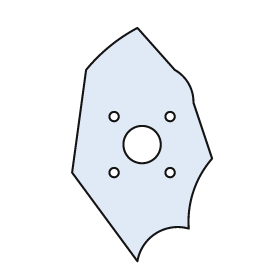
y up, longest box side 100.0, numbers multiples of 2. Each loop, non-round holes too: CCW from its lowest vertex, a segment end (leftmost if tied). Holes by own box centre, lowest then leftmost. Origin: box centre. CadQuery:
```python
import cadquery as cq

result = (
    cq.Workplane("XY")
    .moveTo(-2.0, -50.0)
    .threePointArc((6.0, -38.0), (20.0, -36.0))
    .threePointArc((22.0, -20.0), (30.0, -6.0))
    .lineTo(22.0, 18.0)
    .threePointArc((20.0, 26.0), (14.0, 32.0))
    .lineTo(-2.0, 50.0)
    .threePointArc((-14.0, 42.0), (-24.0, 32.0))
    .lineTo(-30.0, -12.0)
    .close()
    .moveTo(-12.0, -12.0)
    .circle(2.0)
    .moveTo(12.0, -12.0)
    .circle(2.0)
    .moveTo(0.0, 0.0)
    .circle(8.0)
    .moveTo(-12.0, 12.0)
    .circle(2.0)
    .moveTo(12.0, 12.0)
    .circle(2.0)
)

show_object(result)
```